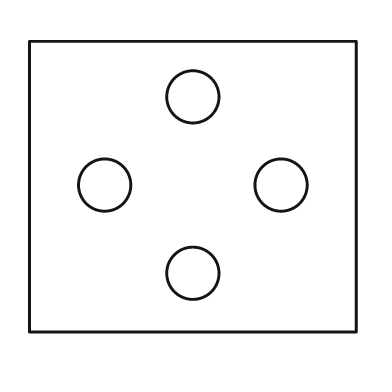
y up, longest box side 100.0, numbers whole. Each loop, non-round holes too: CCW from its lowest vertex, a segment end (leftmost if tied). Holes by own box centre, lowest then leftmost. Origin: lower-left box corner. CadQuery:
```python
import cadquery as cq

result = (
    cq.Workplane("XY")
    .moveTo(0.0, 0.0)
    .lineTo(100.0, 0.0)
    .lineTo(100.0, 89.0)
    .lineTo(0.0, 89.0)
    .close()
    .moveTo(50.0, 18.0)
    .circle(8.0)
    .moveTo(23.0, 45.0)
    .circle(8.0)
    .moveTo(77.0, 45.0)
    .circle(8.0)
    .moveTo(50.0, 72.0)
    .circle(8.0)
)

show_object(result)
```